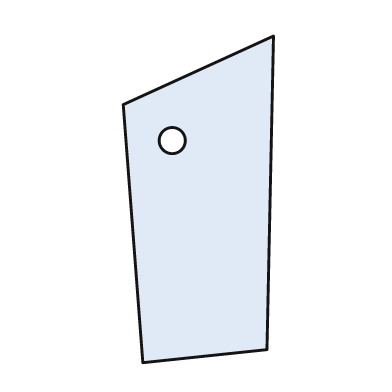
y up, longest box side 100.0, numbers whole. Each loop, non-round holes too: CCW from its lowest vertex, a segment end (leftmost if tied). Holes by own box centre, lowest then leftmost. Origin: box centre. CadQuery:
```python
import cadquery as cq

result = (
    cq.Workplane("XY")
    .moveTo(-17.0, -50.0)
    .lineTo(21.0, -46.0)
    .lineTo(23.0, 50.0)
    .lineTo(-23.0, 29.0)
    .close()
    .moveTo(-8.0, 18.0)
    .circle(4.0)
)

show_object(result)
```